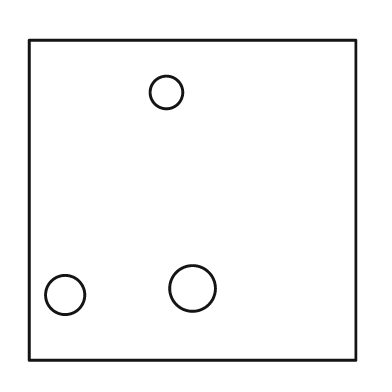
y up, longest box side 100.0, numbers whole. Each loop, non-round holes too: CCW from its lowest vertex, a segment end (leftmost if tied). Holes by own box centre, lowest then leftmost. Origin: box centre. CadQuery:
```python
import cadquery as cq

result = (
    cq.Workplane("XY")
    .moveTo(-50.0, -49.0)
    .lineTo(50.0, -49.0)
    .lineTo(50.0, 49.0)
    .lineTo(-50.0, 49.0)
    .close()
    .moveTo(-39.0, -29.0)
    .circle(6.0)
    .moveTo(0.0, -27.0)
    .circle(7.0)
    .moveTo(-8.0, 33.0)
    .circle(5.0)
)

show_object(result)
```